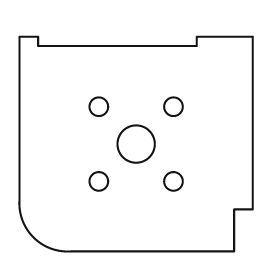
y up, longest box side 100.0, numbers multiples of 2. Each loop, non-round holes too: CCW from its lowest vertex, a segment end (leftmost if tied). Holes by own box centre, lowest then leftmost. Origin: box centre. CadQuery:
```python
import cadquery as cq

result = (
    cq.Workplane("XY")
    .moveTo(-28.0, -46.0)
    .lineTo(42.0, -46.0)
    .lineTo(42.0, -28.0)
    .lineTo(50.0, -28.0)
    .lineTo(50.0, 46.0)
    .lineTo(26.0, 46.0)
    .lineTo(26.0, 42.0)
    .lineTo(-42.0, 42.0)
    .lineTo(-42.0, 46.0)
    .lineTo(-50.0, 46.0)
    .lineTo(-50.0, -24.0)
    .threePointArc((-44.0, -40.0), (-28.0, -46.0))
    .close()
    .moveTo(-16.0, -16.0)
    .circle(4.0)
    .moveTo(16.0, -16.0)
    .circle(4.0)
    .moveTo(0.0, 0.0)
    .circle(8.0)
    .moveTo(-16.0, 16.0)
    .circle(4.0)
    .moveTo(16.0, 16.0)
    .circle(4.0)
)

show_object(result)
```